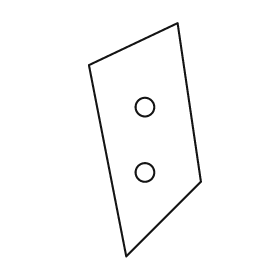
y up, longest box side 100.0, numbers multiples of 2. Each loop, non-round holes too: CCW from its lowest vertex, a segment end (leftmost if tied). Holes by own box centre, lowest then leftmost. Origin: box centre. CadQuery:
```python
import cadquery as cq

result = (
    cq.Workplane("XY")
    .moveTo(-8.0, -50.0)
    .lineTo(24.0, -18.0)
    .lineTo(14.0, 50.0)
    .lineTo(-24.0, 32.0)
    .close()
    .moveTo(0.0, -14.0)
    .circle(4.0)
    .moveTo(0.0, 14.0)
    .circle(4.0)
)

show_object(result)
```